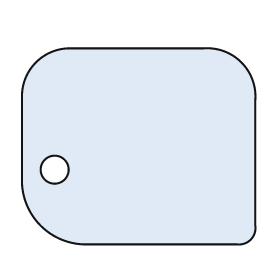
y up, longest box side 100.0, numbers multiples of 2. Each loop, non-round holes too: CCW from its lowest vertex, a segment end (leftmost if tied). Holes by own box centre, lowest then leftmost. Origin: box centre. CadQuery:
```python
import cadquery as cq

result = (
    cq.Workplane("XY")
    .moveTo(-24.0, -42.0)
    .lineTo(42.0, -42.0)
    .threePointArc((48.0, -40.0), (50.0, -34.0))
    .lineTo(50.0, 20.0)
    .threePointArc((44.0, 36.0), (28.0, 42.0))
    .lineTo(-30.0, 42.0)
    .threePointArc((-44.0, 36.0), (-50.0, 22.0))
    .lineTo(-50.0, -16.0)
    .threePointArc((-42.0, -34.0), (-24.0, -42.0))
    .close()
    .moveTo(-36.0, -10.0)
    .circle(6.0)
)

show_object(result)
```